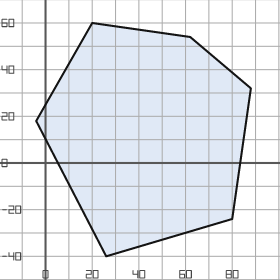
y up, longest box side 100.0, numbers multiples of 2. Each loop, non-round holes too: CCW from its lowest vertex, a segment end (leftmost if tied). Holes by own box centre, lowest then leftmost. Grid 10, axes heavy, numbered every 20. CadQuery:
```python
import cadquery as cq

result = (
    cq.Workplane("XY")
    .moveTo(26.0, -40.0)
    .lineTo(80.0, -24.0)
    .lineTo(88.0, 32.0)
    .lineTo(62.0, 54.0)
    .lineTo(20.0, 60.0)
    .lineTo(-4.0, 18.0)
    .close()
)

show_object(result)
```